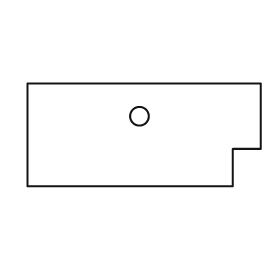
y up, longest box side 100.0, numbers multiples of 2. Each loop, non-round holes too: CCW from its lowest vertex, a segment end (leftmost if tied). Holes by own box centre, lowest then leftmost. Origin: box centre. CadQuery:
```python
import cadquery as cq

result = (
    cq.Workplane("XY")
    .moveTo(-50.0, -22.0)
    .lineTo(38.0, -22.0)
    .lineTo(38.0, -6.0)
    .lineTo(50.0, -6.0)
    .lineTo(50.0, 22.0)
    .lineTo(-50.0, 22.0)
    .close()
    .moveTo(-2.0, 8.0)
    .circle(4.0)
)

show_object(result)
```